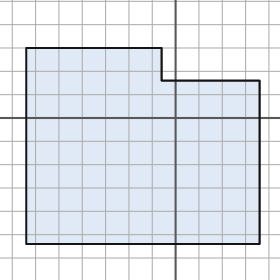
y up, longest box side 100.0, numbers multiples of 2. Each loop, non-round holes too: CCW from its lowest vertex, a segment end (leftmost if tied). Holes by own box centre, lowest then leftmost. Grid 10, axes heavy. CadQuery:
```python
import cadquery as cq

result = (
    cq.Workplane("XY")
    .moveTo(-64.0, -54.0)
    .lineTo(36.0, -54.0)
    .lineTo(36.0, 16.0)
    .lineTo(-6.0, 16.0)
    .lineTo(-6.0, 30.0)
    .lineTo(-64.0, 30.0)
    .close()
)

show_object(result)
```